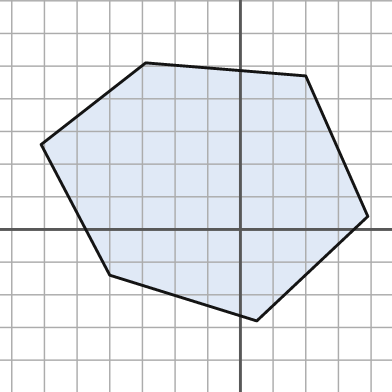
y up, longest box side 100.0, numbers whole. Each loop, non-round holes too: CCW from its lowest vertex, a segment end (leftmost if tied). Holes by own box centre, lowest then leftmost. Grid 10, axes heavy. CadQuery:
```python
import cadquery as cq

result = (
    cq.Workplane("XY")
    .moveTo(5.0, -28.0)
    .lineTo(39.0, 4.0)
    .lineTo(20.0, 47.0)
    .lineTo(-29.0, 51.0)
    .lineTo(-61.0, 26.0)
    .lineTo(-40.0, -14.0)
    .close()
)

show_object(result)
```